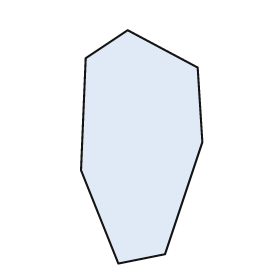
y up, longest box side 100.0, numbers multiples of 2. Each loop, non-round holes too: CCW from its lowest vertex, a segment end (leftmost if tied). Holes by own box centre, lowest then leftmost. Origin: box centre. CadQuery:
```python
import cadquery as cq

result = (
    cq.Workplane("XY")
    .moveTo(-10.0, -50.0)
    .lineTo(10.0, -46.0)
    .lineTo(26.0, 2.0)
    .lineTo(24.0, 34.0)
    .lineTo(-6.0, 50.0)
    .lineTo(-24.0, 38.0)
    .lineTo(-26.0, -10.0)
    .close()
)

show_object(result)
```